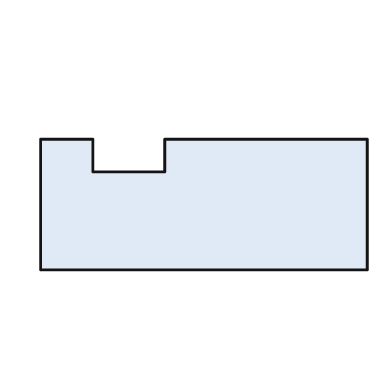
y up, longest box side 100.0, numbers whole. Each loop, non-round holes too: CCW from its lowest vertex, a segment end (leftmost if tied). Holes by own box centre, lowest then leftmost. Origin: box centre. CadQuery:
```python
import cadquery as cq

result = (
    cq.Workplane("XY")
    .moveTo(-50.0, -20.0)
    .lineTo(50.0, -20.0)
    .lineTo(50.0, 20.0)
    .lineTo(-12.0, 20.0)
    .lineTo(-12.0, 10.0)
    .lineTo(-34.0, 10.0)
    .lineTo(-34.0, 20.0)
    .lineTo(-50.0, 20.0)
    .close()
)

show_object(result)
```